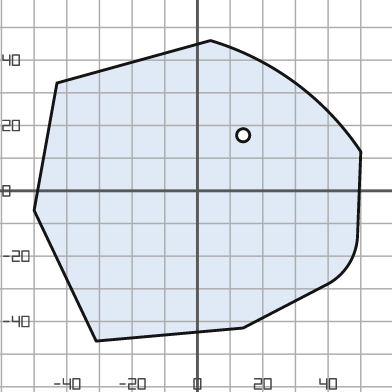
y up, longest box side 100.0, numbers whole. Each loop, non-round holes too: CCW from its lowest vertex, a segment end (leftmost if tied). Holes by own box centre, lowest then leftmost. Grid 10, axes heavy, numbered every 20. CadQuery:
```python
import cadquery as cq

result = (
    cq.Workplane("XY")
    .moveTo(-31.0, -46.0)
    .lineTo(14.0, -42.0)
    .lineTo(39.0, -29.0)
    .threePointArc((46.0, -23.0), (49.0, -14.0))
    .lineTo(50.0, 12.0)
    .threePointArc((30.0, 33.0), (4.0, 46.0))
    .lineTo(-43.0, 33.0)
    .lineTo(-50.0, -6.0)
    .close()
    .moveTo(14.0, 17.0)
    .circle(2.0)
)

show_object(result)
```